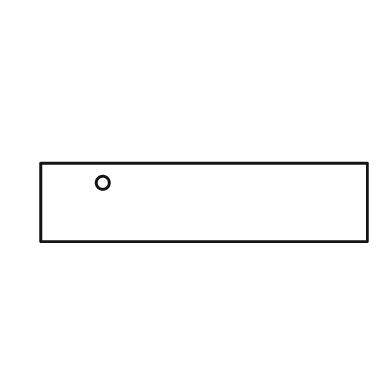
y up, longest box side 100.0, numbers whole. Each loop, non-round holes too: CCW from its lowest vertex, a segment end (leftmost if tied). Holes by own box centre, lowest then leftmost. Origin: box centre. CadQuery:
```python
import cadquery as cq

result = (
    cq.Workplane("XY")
    .moveTo(-50.0, -12.0)
    .lineTo(50.0, -12.0)
    .lineTo(50.0, 12.0)
    .lineTo(-50.0, 12.0)
    .close()
    .moveTo(-31.0, 6.0)
    .circle(2.0)
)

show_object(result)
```